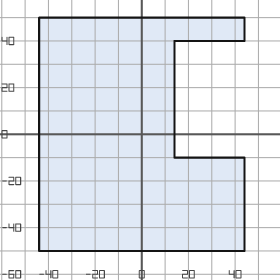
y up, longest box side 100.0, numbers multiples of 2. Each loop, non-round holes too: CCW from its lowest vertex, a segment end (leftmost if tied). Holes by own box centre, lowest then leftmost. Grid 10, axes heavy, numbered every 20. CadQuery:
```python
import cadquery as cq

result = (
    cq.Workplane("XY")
    .moveTo(-44.0, -50.0)
    .lineTo(44.0, -50.0)
    .lineTo(44.0, -10.0)
    .lineTo(14.0, -10.0)
    .lineTo(14.0, 40.0)
    .lineTo(44.0, 40.0)
    .lineTo(44.0, 50.0)
    .lineTo(-44.0, 50.0)
    .close()
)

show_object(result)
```